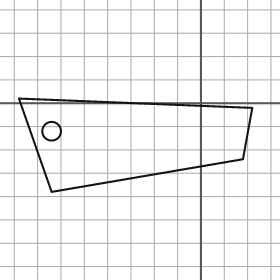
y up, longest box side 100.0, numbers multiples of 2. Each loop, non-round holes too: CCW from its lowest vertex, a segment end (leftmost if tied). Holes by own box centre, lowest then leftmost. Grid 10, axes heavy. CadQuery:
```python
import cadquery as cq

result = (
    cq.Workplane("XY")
    .moveTo(-64.0, -38.0)
    .lineTo(18.0, -24.0)
    .lineTo(22.0, -2.0)
    .lineTo(-78.0, 2.0)
    .close()
    .moveTo(-64.0, -12.0)
    .circle(4.0)
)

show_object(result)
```